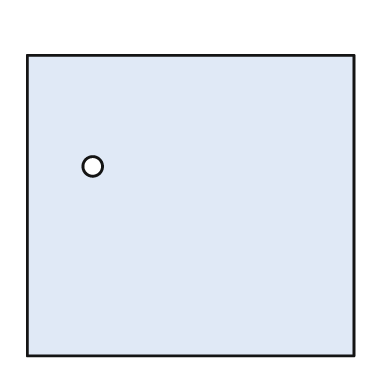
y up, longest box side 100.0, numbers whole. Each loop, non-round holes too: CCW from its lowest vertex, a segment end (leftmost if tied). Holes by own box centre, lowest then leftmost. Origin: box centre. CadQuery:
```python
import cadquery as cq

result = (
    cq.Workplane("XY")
    .moveTo(-50.0, -46.0)
    .lineTo(50.0, -46.0)
    .lineTo(50.0, 46.0)
    .lineTo(-50.0, 46.0)
    .close()
    .moveTo(-30.0, 12.0)
    .circle(3.0)
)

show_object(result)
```